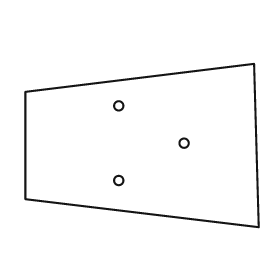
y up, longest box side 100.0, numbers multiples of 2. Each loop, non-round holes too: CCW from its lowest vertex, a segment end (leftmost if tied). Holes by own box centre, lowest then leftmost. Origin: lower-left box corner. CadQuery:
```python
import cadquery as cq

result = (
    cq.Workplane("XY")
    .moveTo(100.0, 0.0)
    .lineTo(98.0, 70.0)
    .lineTo(0.0, 58.0)
    .lineTo(0.0, 12.0)
    .close()
    .moveTo(40.0, 20.0)
    .circle(2.0)
    .moveTo(68.0, 36.0)
    .circle(2.0)
    .moveTo(40.0, 52.0)
    .circle(2.0)
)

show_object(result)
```